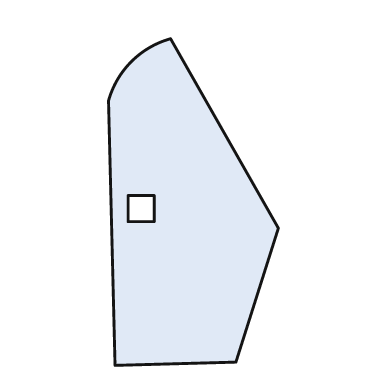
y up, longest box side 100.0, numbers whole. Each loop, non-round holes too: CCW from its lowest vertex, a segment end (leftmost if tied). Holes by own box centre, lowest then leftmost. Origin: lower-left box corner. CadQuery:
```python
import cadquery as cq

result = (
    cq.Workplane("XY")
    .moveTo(2.0, 0.0)
    .lineTo(39.0, 1.0)
    .lineTo(52.0, 42.0)
    .lineTo(19.0, 100.0)
    .threePointArc((7.0, 93.0), (0.0, 81.0))
    .close()
    .moveTo(6.0, 44.0)
    .lineTo(14.0, 44.0)
    .lineTo(14.0, 52.0)
    .lineTo(6.0, 52.0)
    .close()
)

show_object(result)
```